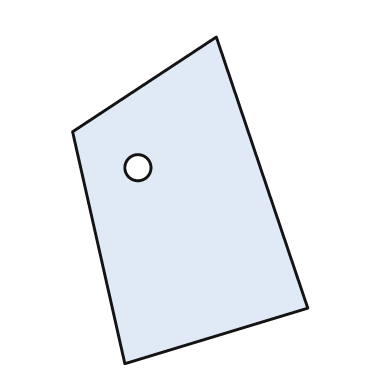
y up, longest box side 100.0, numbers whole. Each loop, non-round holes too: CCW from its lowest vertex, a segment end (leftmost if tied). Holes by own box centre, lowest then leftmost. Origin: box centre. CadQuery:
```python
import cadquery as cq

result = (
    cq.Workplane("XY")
    .moveTo(-20.0, -50.0)
    .lineTo(36.0, -33.0)
    .lineTo(8.0, 50.0)
    .lineTo(-36.0, 21.0)
    .close()
    .moveTo(-16.0, 10.0)
    .circle(4.0)
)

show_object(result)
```